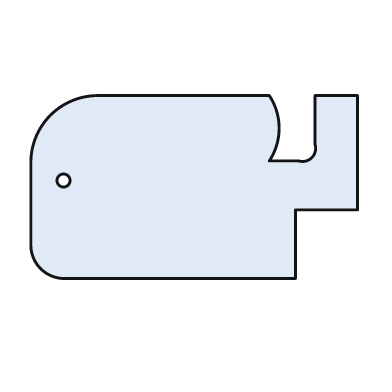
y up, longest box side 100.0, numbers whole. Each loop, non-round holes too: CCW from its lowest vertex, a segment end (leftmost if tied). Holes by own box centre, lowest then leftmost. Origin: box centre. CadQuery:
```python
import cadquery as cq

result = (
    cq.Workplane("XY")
    .moveTo(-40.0, -28.0)
    .lineTo(31.0, -28.0)
    .lineTo(31.0, -7.0)
    .lineTo(50.0, -7.0)
    .lineTo(50.0, 28.0)
    .lineTo(37.0, 28.0)
    .lineTo(37.0, 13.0)
    .threePointArc((36.0, 9.0), (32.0, 8.0))
    .lineTo(23.0, 8.0)
    .threePointArc((26.0, 18.0), (23.0, 28.0))
    .lineTo(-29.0, 28.0)
    .threePointArc((-44.0, 22.0), (-50.0, 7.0))
    .lineTo(-50.0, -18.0)
    .threePointArc((-47.0, -25.0), (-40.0, -28.0))
    .close()
    .moveTo(-40.0, 2.0)
    .circle(2.0)
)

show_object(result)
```